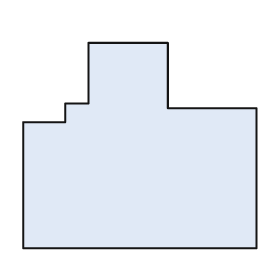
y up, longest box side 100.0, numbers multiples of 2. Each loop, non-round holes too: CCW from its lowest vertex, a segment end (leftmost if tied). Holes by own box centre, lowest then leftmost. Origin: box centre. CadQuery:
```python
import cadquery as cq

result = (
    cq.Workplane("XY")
    .moveTo(-50.0, -44.0)
    .lineTo(50.0, -44.0)
    .lineTo(50.0, 16.0)
    .lineTo(12.0, 16.0)
    .lineTo(12.0, 44.0)
    .lineTo(-22.0, 44.0)
    .lineTo(-22.0, 18.0)
    .lineTo(-32.0, 18.0)
    .lineTo(-32.0, 10.0)
    .lineTo(-50.0, 10.0)
    .close()
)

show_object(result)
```